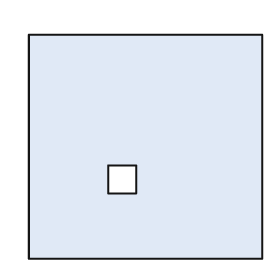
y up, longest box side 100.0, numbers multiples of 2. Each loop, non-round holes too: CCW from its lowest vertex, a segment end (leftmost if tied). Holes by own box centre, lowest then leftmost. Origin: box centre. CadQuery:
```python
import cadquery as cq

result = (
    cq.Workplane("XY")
    .moveTo(-50.0, -48.0)
    .lineTo(50.0, -48.0)
    .lineTo(50.0, 48.0)
    .lineTo(-50.0, 48.0)
    .close()
    .moveTo(-16.0, -20.0)
    .lineTo(-4.0, -20.0)
    .lineTo(-4.0, -8.0)
    .lineTo(-16.0, -8.0)
    .close()
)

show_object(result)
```